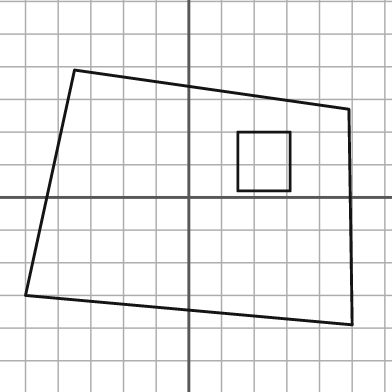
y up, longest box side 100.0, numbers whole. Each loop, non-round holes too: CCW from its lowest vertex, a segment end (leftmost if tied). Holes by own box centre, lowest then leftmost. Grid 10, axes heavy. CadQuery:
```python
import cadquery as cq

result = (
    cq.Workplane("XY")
    .moveTo(50.0, -39.0)
    .lineTo(49.0, 27.0)
    .lineTo(-35.0, 39.0)
    .lineTo(-50.0, -30.0)
    .close()
    .moveTo(15.0, 2.0)
    .lineTo(31.0, 2.0)
    .lineTo(31.0, 20.0)
    .lineTo(15.0, 20.0)
    .close()
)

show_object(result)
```